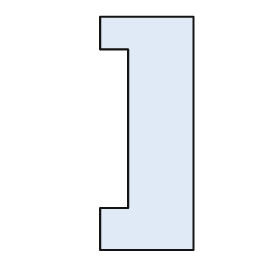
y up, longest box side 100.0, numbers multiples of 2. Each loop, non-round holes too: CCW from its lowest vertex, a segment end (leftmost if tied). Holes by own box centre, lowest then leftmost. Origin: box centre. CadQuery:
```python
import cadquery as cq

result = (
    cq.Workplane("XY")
    .moveTo(-20.0, -50.0)
    .lineTo(20.0, -50.0)
    .lineTo(20.0, 50.0)
    .lineTo(-20.0, 50.0)
    .lineTo(-20.0, 36.0)
    .lineTo(-8.0, 36.0)
    .lineTo(-8.0, -32.0)
    .lineTo(-20.0, -32.0)
    .close()
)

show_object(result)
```